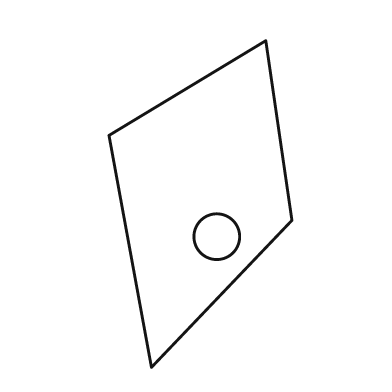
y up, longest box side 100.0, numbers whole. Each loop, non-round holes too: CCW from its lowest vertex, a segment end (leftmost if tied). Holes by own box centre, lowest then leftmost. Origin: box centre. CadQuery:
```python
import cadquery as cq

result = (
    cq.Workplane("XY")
    .moveTo(-15.0, -50.0)
    .lineTo(28.0, -5.0)
    .lineTo(20.0, 50.0)
    .lineTo(-28.0, 21.0)
    .close()
    .moveTo(5.0, -10.0)
    .circle(7.0)
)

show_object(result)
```